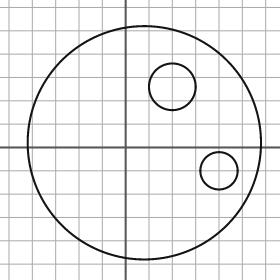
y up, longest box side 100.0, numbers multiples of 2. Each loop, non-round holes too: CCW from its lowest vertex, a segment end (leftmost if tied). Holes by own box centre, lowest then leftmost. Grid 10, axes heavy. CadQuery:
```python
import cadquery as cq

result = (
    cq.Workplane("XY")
    .moveTo(8.0, 2.0)
    .circle(50.0)
    .moveTo(40.0, -10.0)
    .circle(8.0)
    .moveTo(20.0, 26.0)
    .circle(10.0)
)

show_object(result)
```